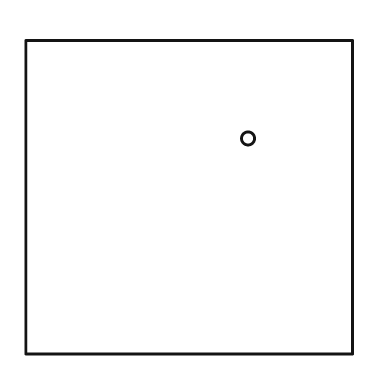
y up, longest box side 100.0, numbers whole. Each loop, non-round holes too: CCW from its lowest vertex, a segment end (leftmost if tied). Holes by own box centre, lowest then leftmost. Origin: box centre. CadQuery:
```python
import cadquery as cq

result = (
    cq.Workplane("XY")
    .moveTo(-50.0, -48.0)
    .lineTo(50.0, -48.0)
    .lineTo(50.0, 48.0)
    .lineTo(-50.0, 48.0)
    .close()
    .moveTo(18.0, 18.0)
    .circle(2.0)
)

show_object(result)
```